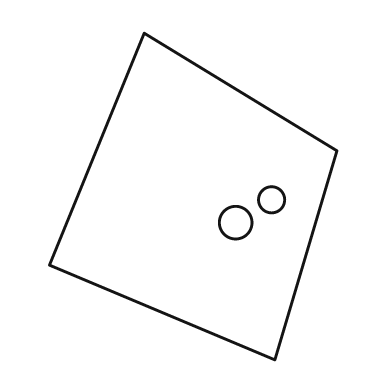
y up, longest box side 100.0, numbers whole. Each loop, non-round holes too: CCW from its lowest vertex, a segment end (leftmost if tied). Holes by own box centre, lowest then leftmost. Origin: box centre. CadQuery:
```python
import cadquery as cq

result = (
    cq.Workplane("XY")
    .moveTo(25.0, -50.0)
    .lineTo(44.0, 14.0)
    .lineTo(-15.0, 50.0)
    .lineTo(-44.0, -21.0)
    .close()
    .moveTo(13.0, -8.0)
    .circle(5.0)
    .moveTo(24.0, -1.0)
    .circle(4.0)
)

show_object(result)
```